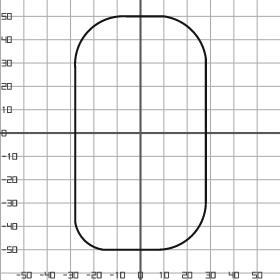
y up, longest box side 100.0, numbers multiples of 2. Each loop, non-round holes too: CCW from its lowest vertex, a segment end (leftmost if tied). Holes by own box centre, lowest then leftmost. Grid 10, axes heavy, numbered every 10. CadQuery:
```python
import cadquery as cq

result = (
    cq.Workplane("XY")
    .moveTo(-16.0, -50.0)
    .lineTo(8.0, -50.0)
    .threePointArc((22.0, -44.0), (28.0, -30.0))
    .lineTo(28.0, 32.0)
    .threePointArc((22.0, 44.0), (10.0, 50.0))
    .lineTo(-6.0, 50.0)
    .threePointArc((-22.0, 44.0), (-28.0, 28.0))
    .lineTo(-28.0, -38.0)
    .threePointArc((-24.0, -46.0), (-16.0, -50.0))
    .close()
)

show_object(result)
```